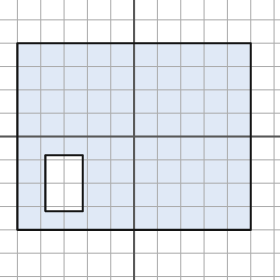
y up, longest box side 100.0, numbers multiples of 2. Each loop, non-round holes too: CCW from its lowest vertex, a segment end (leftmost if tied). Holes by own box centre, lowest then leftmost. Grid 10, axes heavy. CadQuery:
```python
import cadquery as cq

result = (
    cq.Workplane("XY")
    .moveTo(-50.0, -40.0)
    .lineTo(50.0, -40.0)
    .lineTo(50.0, 40.0)
    .lineTo(-50.0, 40.0)
    .close()
    .moveTo(-38.0, -32.0)
    .lineTo(-22.0, -32.0)
    .lineTo(-22.0, -8.0)
    .lineTo(-38.0, -8.0)
    .close()
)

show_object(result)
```